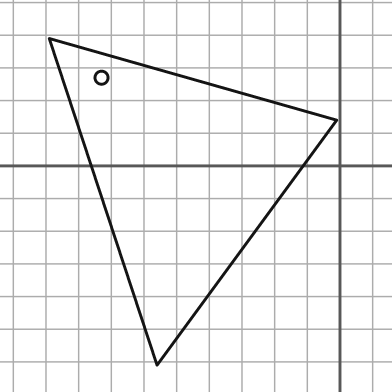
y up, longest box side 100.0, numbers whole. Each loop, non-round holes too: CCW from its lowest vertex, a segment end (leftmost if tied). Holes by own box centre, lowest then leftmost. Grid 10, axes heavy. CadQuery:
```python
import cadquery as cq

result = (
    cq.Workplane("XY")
    .moveTo(-56.0, -61.0)
    .lineTo(-1.0, 14.0)
    .lineTo(-89.0, 39.0)
    .close()
    .moveTo(-73.0, 27.0)
    .circle(2.0)
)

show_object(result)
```